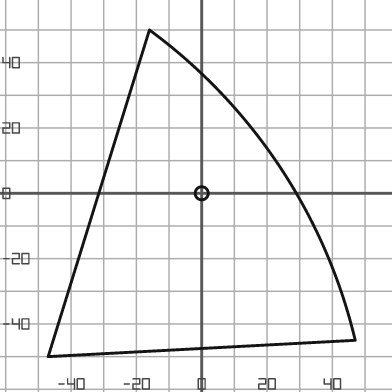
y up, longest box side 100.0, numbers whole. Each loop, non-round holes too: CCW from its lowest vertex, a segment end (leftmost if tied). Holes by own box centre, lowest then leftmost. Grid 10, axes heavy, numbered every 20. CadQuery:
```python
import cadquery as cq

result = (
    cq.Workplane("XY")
    .moveTo(-47.0, -50.0)
    .lineTo(47.0, -45.0)
    .threePointArc((24.0, 8.0), (-16.0, 50.0))
    .close()
    .moveTo(0.0, 0.0)
    .circle(2.0)
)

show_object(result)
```